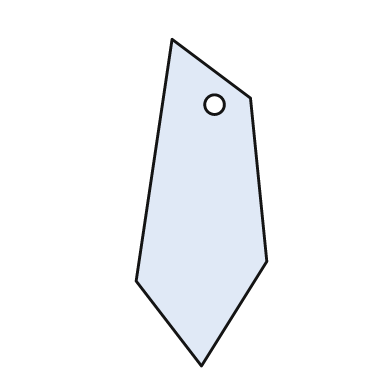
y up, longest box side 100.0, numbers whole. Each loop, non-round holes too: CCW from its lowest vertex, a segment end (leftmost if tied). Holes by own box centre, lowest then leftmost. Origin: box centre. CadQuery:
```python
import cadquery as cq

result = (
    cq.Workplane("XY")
    .moveTo(0.0, -50.0)
    .lineTo(20.0, -18.0)
    .lineTo(15.0, 32.0)
    .lineTo(-9.0, 50.0)
    .lineTo(-20.0, -24.0)
    .close()
    .moveTo(4.0, 30.0)
    .circle(3.0)
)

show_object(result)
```